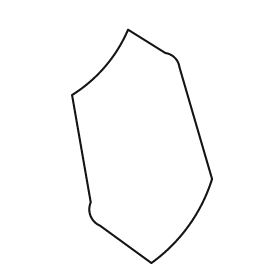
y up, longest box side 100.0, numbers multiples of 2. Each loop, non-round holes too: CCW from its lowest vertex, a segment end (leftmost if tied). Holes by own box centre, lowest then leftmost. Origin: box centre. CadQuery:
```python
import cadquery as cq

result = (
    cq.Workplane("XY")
    .moveTo(4.0, -50.0)
    .threePointArc((20.0, -34.0), (30.0, -14.0))
    .lineTo(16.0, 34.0)
    .threePointArc((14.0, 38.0), (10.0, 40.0))
    .lineTo(-6.0, 50.0)
    .threePointArc((-16.0, 34.0), (-30.0, 22.0))
    .lineTo(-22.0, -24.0)
    .threePointArc((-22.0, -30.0), (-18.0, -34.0))
    .close()
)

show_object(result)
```